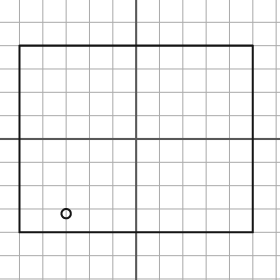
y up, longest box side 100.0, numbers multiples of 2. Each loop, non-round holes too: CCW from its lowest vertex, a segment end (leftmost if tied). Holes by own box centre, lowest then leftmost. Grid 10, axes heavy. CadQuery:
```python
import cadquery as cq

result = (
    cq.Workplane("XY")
    .moveTo(-50.0, -40.0)
    .lineTo(50.0, -40.0)
    .lineTo(50.0, 40.0)
    .lineTo(-50.0, 40.0)
    .close()
    .moveTo(-30.0, -32.0)
    .circle(2.0)
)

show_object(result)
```